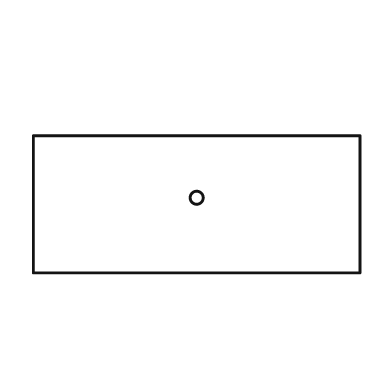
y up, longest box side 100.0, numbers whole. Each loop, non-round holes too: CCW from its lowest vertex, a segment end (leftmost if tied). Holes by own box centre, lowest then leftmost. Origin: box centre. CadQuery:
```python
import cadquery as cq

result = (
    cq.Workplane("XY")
    .moveTo(-50.0, -21.0)
    .lineTo(50.0, -21.0)
    .lineTo(50.0, 21.0)
    .lineTo(-50.0, 21.0)
    .close()
    .moveTo(0.0, 2.0)
    .circle(2.0)
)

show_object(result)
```